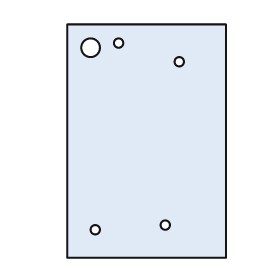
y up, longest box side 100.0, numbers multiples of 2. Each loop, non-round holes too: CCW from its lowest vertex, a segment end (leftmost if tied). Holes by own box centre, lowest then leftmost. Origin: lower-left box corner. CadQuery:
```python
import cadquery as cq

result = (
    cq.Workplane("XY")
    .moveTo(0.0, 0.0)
    .lineTo(68.0, 0.0)
    .lineTo(68.0, 100.0)
    .lineTo(0.0, 100.0)
    .close()
    .moveTo(12.0, 12.0)
    .circle(2.0)
    .moveTo(42.0, 14.0)
    .circle(2.0)
    .moveTo(48.0, 84.0)
    .circle(2.0)
    .moveTo(10.0, 90.0)
    .circle(4.0)
    .moveTo(22.0, 92.0)
    .circle(2.0)
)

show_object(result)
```